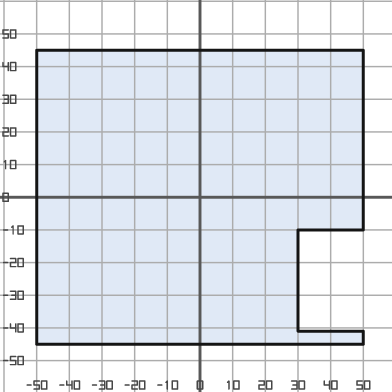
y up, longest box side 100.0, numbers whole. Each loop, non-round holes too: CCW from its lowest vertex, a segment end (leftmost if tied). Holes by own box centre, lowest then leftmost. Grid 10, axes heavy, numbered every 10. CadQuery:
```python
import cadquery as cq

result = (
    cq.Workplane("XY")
    .moveTo(-50.0, -45.0)
    .lineTo(50.0, -45.0)
    .lineTo(50.0, -41.0)
    .lineTo(30.0, -41.0)
    .lineTo(30.0, -10.0)
    .lineTo(50.0, -10.0)
    .lineTo(50.0, 45.0)
    .lineTo(-50.0, 45.0)
    .close()
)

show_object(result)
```